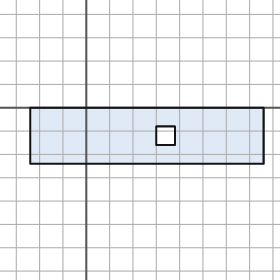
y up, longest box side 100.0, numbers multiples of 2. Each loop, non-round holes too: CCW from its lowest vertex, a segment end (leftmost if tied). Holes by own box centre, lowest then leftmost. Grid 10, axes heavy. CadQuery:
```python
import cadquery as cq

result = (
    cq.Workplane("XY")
    .moveTo(-24.0, -24.0)
    .lineTo(76.0, -24.0)
    .lineTo(76.0, 0.0)
    .lineTo(-24.0, 0.0)
    .close()
    .moveTo(30.0, -16.0)
    .lineTo(38.0, -16.0)
    .lineTo(38.0, -8.0)
    .lineTo(30.0, -8.0)
    .close()
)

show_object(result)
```